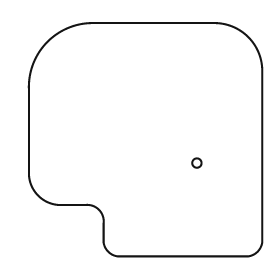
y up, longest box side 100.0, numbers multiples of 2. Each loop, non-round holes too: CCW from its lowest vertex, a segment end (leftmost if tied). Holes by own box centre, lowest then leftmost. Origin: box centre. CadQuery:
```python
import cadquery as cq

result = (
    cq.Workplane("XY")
    .moveTo(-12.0, -50.0)
    .lineTo(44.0, -50.0)
    .threePointArc((48.0, -48.0), (50.0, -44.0))
    .lineTo(50.0, 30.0)
    .threePointArc((44.0, 44.0), (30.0, 50.0))
    .lineTo(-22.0, 50.0)
    .threePointArc((-42.0, 42.0), (-50.0, 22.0))
    .lineTo(-50.0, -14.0)
    .threePointArc((-46.0, -24.0), (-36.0, -28.0))
    .lineTo(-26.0, -28.0)
    .threePointArc((-20.0, -30.0), (-18.0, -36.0))
    .lineTo(-18.0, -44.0)
    .threePointArc((-16.0, -48.0), (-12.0, -50.0))
    .close()
    .moveTo(22.0, -10.0)
    .circle(2.0)
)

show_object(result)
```